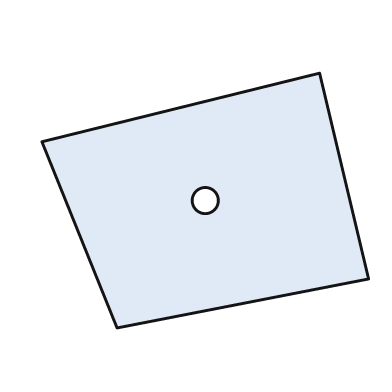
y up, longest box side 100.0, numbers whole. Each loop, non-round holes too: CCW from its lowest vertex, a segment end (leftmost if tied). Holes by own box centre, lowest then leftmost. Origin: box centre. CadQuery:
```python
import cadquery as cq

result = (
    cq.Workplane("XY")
    .moveTo(-27.0, -39.0)
    .lineTo(50.0, -24.0)
    .lineTo(35.0, 39.0)
    .lineTo(-50.0, 18.0)
    .close()
    .moveTo(0.0, 0.0)
    .circle(4.0)
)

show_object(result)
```